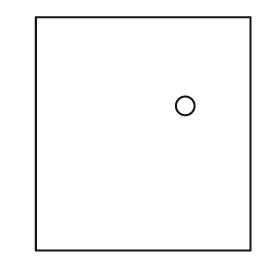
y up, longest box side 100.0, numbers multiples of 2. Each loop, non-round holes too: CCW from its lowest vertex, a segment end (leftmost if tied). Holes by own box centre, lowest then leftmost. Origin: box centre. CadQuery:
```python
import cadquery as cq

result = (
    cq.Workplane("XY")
    .moveTo(-46.0, -50.0)
    .lineTo(46.0, -50.0)
    .lineTo(46.0, 50.0)
    .lineTo(-46.0, 50.0)
    .close()
    .moveTo(18.0, 12.0)
    .circle(4.0)
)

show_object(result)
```